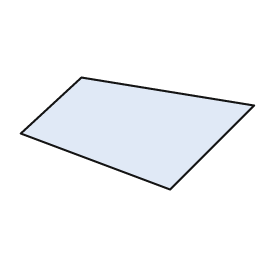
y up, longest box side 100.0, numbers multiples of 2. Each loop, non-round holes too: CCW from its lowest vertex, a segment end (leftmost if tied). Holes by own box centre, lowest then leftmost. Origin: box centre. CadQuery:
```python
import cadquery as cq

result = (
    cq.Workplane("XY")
    .moveTo(14.0, -24.0)
    .lineTo(50.0, 12.0)
    .lineTo(-24.0, 24.0)
    .lineTo(-50.0, 0.0)
    .close()
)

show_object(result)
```